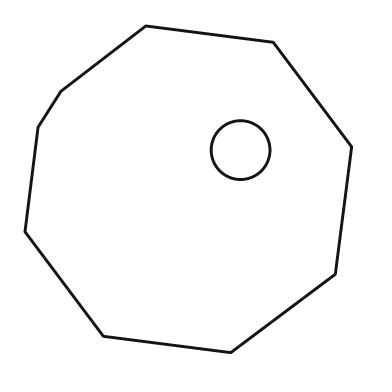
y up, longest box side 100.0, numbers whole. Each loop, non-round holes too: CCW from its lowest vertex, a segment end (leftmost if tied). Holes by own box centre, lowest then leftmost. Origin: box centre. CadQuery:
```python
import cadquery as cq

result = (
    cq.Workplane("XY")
    .moveTo(13.0, -50.0)
    .lineTo(45.0, -26.0)
    .lineTo(50.0, 13.0)
    .lineTo(26.0, 45.0)
    .lineTo(-13.0, 50.0)
    .lineTo(-39.0, 30.0)
    .lineTo(-46.0, 19.0)
    .lineTo(-50.0, -13.0)
    .lineTo(-26.0, -45.0)
    .close()
    .moveTo(16.0, 12.0)
    .circle(9.0)
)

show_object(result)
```